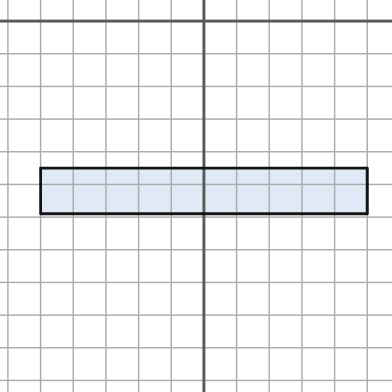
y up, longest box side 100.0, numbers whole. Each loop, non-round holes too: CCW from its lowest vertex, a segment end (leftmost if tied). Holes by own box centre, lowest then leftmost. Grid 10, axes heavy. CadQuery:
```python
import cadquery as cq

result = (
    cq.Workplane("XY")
    .moveTo(-50.0, -59.0)
    .lineTo(50.0, -59.0)
    .lineTo(50.0, -45.0)
    .lineTo(-50.0, -45.0)
    .close()
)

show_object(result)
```